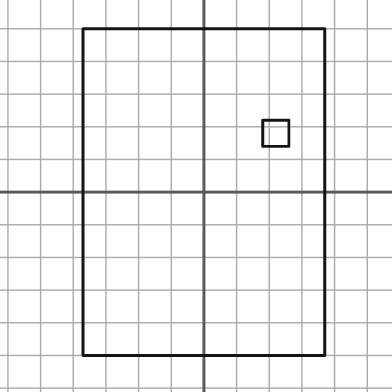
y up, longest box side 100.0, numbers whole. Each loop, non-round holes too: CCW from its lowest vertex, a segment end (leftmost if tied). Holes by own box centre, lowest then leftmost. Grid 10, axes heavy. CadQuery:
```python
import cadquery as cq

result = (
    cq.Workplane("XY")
    .moveTo(-37.0, -50.0)
    .lineTo(37.0, -50.0)
    .lineTo(37.0, 50.0)
    .lineTo(-37.0, 50.0)
    .close()
    .moveTo(18.0, 14.0)
    .lineTo(26.0, 14.0)
    .lineTo(26.0, 22.0)
    .lineTo(18.0, 22.0)
    .close()
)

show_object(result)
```